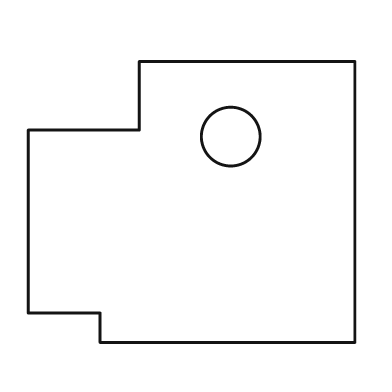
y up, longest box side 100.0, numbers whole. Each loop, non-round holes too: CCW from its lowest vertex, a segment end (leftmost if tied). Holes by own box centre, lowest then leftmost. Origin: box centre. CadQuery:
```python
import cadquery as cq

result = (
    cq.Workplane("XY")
    .moveTo(-28.0, -43.0)
    .lineTo(50.0, -43.0)
    .lineTo(50.0, 43.0)
    .lineTo(-16.0, 43.0)
    .lineTo(-16.0, 22.0)
    .lineTo(-50.0, 22.0)
    .lineTo(-50.0, -34.0)
    .lineTo(-28.0, -34.0)
    .close()
    .moveTo(12.0, 20.0)
    .circle(9.0)
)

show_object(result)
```